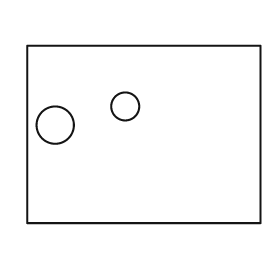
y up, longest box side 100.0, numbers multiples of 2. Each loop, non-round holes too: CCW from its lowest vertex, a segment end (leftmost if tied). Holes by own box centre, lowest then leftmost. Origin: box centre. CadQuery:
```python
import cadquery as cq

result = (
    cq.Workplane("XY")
    .moveTo(-50.0, -38.0)
    .lineTo(50.0, -38.0)
    .lineTo(50.0, 38.0)
    .lineTo(-50.0, 38.0)
    .close()
    .moveTo(-38.0, 4.0)
    .circle(8.0)
    .moveTo(-8.0, 12.0)
    .circle(6.0)
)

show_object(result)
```